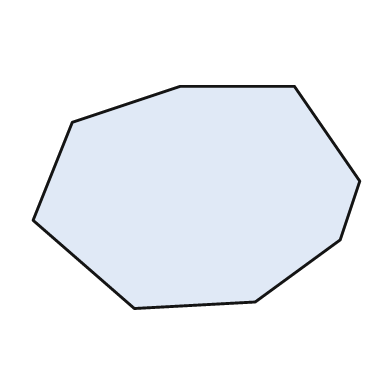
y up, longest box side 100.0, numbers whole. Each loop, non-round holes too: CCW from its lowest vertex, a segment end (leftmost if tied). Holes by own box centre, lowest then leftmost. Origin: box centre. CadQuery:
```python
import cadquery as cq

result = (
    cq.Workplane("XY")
    .moveTo(-19.0, -34.0)
    .lineTo(18.0, -32.0)
    .lineTo(44.0, -13.0)
    .lineTo(50.0, 5.0)
    .lineTo(30.0, 34.0)
    .lineTo(-5.0, 34.0)
    .lineTo(-38.0, 23.0)
    .lineTo(-50.0, -7.0)
    .close()
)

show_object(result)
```